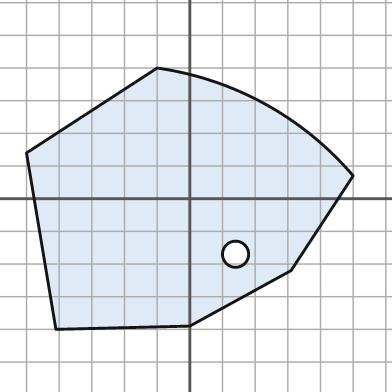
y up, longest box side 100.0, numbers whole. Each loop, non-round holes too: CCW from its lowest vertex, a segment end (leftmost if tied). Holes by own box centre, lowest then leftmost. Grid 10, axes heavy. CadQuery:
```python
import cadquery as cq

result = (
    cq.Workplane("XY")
    .moveTo(-41.0, -40.0)
    .lineTo(0.0, -39.0)
    .lineTo(31.0, -22.0)
    .lineTo(50.0, 7.0)
    .threePointArc((23.0, 29.0), (-10.0, 40.0))
    .lineTo(-50.0, 14.0)
    .close()
    .moveTo(14.0, -17.0)
    .circle(4.0)
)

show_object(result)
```